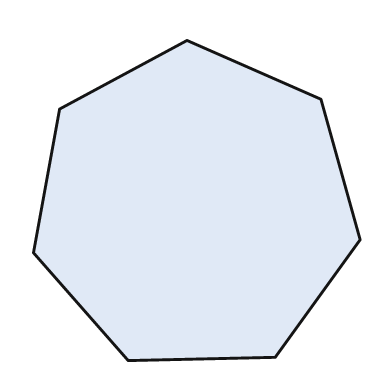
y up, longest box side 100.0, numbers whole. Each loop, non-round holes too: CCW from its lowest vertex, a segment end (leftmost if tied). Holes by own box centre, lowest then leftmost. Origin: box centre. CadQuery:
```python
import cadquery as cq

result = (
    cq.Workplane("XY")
    .moveTo(-21.0, -49.0)
    .lineTo(24.0, -48.0)
    .lineTo(50.0, -12.0)
    .lineTo(38.0, 31.0)
    .lineTo(-3.0, 49.0)
    .lineTo(-42.0, 28.0)
    .lineTo(-50.0, -16.0)
    .close()
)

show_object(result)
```